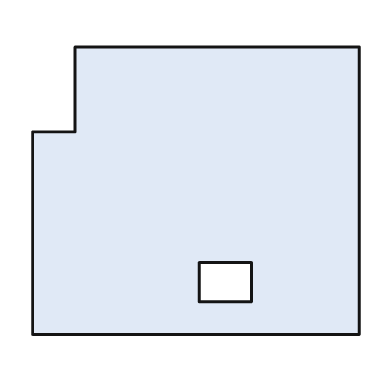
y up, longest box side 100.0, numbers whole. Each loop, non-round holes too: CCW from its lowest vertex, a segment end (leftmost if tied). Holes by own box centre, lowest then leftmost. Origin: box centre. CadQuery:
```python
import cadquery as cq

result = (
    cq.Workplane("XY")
    .moveTo(-50.0, -44.0)
    .lineTo(50.0, -44.0)
    .lineTo(50.0, 44.0)
    .lineTo(-37.0, 44.0)
    .lineTo(-37.0, 18.0)
    .lineTo(-50.0, 18.0)
    .close()
    .moveTo(1.0, -34.0)
    .lineTo(17.0, -34.0)
    .lineTo(17.0, -22.0)
    .lineTo(1.0, -22.0)
    .close()
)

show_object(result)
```